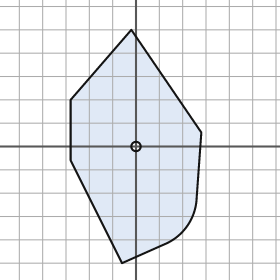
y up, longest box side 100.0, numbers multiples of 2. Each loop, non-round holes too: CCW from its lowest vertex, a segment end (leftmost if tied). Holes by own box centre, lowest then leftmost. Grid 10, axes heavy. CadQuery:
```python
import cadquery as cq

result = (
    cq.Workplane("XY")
    .moveTo(-6.0, -50.0)
    .lineTo(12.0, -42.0)
    .threePointArc((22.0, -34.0), (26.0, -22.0))
    .lineTo(28.0, 6.0)
    .lineTo(-2.0, 50.0)
    .lineTo(-28.0, 20.0)
    .lineTo(-28.0, -6.0)
    .close()
    .moveTo(0.0, 0.0)
    .circle(2.0)
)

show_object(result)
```